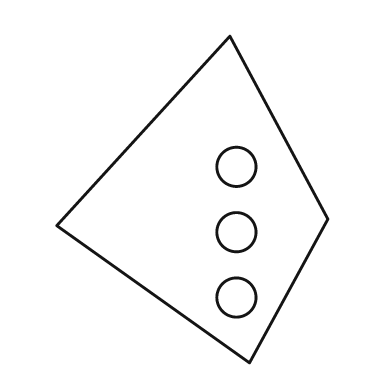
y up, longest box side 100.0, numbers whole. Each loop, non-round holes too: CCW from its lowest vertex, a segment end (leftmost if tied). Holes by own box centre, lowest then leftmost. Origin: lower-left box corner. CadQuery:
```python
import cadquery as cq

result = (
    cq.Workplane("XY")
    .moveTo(59.0, 0.0)
    .lineTo(83.0, 44.0)
    .lineTo(53.0, 100.0)
    .lineTo(0.0, 42.0)
    .close()
    .moveTo(55.0, 20.0)
    .circle(6.0)
    .moveTo(55.0, 40.0)
    .circle(6.0)
    .moveTo(55.0, 60.0)
    .circle(6.0)
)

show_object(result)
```